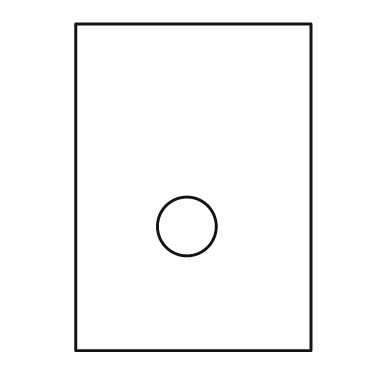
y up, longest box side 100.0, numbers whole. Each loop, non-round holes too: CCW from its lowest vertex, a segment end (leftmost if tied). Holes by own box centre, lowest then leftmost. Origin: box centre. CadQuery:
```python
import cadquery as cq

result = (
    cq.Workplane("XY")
    .moveTo(-36.0, -50.0)
    .lineTo(36.0, -50.0)
    .lineTo(36.0, 50.0)
    .lineTo(-36.0, 50.0)
    .close()
    .moveTo(-2.0, -12.0)
    .circle(9.0)
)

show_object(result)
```